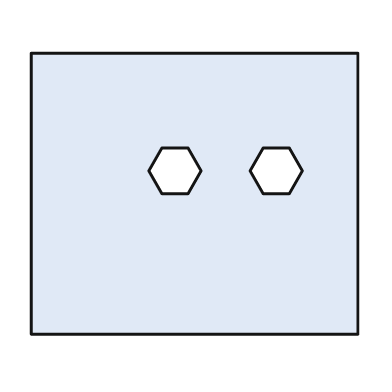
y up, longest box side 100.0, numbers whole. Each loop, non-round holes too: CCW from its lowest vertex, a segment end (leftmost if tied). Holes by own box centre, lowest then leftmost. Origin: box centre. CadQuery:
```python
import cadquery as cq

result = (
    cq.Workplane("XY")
    .moveTo(-50.0, -43.0)
    .lineTo(50.0, -43.0)
    .lineTo(50.0, 43.0)
    .lineTo(-50.0, 43.0)
    .close()
    .moveTo(-10.0, 0.0)
    .lineTo(-2.0, 0.0)
    .lineTo(2.0, 7.0)
    .lineTo(-2.0, 14.0)
    .lineTo(-10.0, 14.0)
    .lineTo(-14.0, 7.0)
    .close()
    .moveTo(21.0, 0.0)
    .lineTo(29.0, 0.0)
    .lineTo(33.0, 7.0)
    .lineTo(29.0, 14.0)
    .lineTo(21.0, 14.0)
    .lineTo(17.0, 7.0)
    .close()
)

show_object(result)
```